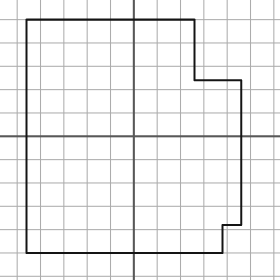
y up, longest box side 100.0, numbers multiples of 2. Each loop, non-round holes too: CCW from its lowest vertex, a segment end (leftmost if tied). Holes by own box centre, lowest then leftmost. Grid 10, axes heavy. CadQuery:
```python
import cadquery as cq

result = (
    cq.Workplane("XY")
    .moveTo(-46.0, -50.0)
    .lineTo(38.0, -50.0)
    .lineTo(38.0, -38.0)
    .lineTo(46.0, -38.0)
    .lineTo(46.0, 24.0)
    .lineTo(26.0, 24.0)
    .lineTo(26.0, 50.0)
    .lineTo(-46.0, 50.0)
    .close()
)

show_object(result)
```